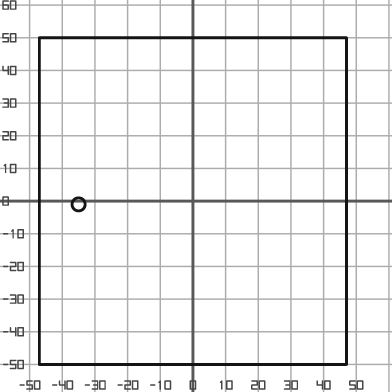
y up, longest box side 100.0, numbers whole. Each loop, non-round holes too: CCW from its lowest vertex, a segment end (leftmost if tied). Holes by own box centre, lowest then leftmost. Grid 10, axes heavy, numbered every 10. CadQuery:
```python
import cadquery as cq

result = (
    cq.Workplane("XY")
    .moveTo(-47.0, -50.0)
    .lineTo(47.0, -50.0)
    .lineTo(47.0, 50.0)
    .lineTo(-47.0, 50.0)
    .close()
    .moveTo(-35.0, -1.0)
    .circle(2.0)
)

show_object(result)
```